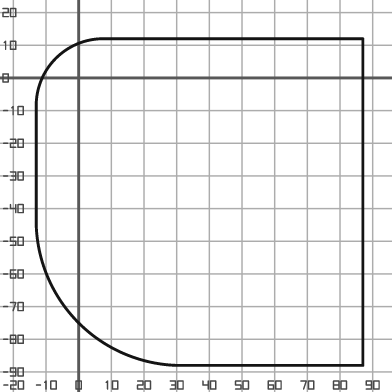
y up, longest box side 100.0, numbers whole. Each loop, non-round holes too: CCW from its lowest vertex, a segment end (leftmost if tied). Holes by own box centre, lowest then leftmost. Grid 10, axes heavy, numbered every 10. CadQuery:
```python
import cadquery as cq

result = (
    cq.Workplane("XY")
    .moveTo(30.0, -88.0)
    .lineTo(87.0, -88.0)
    .lineTo(87.0, 12.0)
    .lineTo(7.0, 12.0)
    .threePointArc((-7.0, 6.0), (-13.0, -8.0))
    .lineTo(-13.0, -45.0)
    .threePointArc((0.0, -75.0), (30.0, -88.0))
    .close()
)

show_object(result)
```